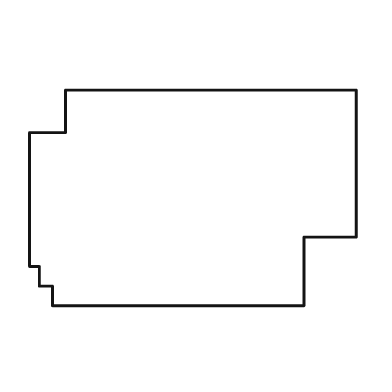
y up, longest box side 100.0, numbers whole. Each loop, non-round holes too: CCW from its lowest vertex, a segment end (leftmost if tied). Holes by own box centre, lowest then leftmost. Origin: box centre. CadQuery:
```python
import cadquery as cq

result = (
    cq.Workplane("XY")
    .moveTo(-43.0, -33.0)
    .lineTo(34.0, -33.0)
    .lineTo(34.0, -12.0)
    .lineTo(50.0, -12.0)
    .lineTo(50.0, 33.0)
    .lineTo(-39.0, 33.0)
    .lineTo(-39.0, 20.0)
    .lineTo(-50.0, 20.0)
    .lineTo(-50.0, -21.0)
    .lineTo(-47.0, -21.0)
    .lineTo(-47.0, -27.0)
    .lineTo(-43.0, -27.0)
    .close()
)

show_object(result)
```